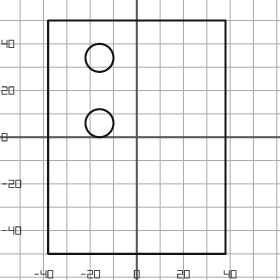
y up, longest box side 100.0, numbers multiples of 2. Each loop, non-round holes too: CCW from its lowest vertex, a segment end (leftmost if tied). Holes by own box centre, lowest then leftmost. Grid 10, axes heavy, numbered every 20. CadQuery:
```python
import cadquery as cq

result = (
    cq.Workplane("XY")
    .moveTo(-38.0, -50.0)
    .lineTo(38.0, -50.0)
    .lineTo(38.0, 50.0)
    .lineTo(-38.0, 50.0)
    .close()
    .moveTo(-16.0, 6.0)
    .circle(6.0)
    .moveTo(-16.0, 34.0)
    .circle(6.0)
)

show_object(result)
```